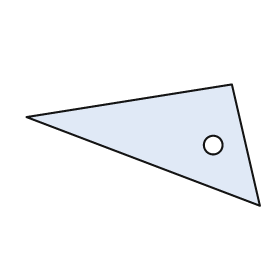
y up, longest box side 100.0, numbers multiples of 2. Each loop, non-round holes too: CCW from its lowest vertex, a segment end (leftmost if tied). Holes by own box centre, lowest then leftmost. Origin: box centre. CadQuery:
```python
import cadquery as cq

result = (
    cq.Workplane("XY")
    .moveTo(50.0, -26.0)
    .lineTo(38.0, 26.0)
    .lineTo(-50.0, 12.0)
    .close()
    .moveTo(30.0, 0.0)
    .circle(4.0)
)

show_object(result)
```